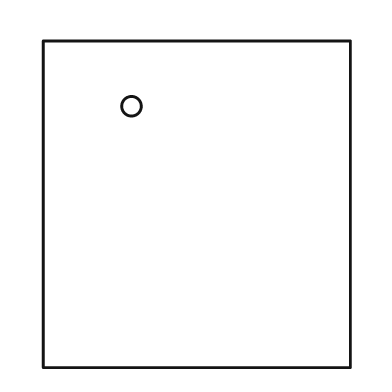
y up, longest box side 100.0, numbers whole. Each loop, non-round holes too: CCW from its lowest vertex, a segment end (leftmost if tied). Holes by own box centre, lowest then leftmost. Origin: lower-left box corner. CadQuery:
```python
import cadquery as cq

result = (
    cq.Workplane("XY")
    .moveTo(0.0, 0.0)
    .lineTo(94.0, 0.0)
    .lineTo(94.0, 100.0)
    .lineTo(0.0, 100.0)
    .close()
    .moveTo(27.0, 80.0)
    .circle(3.0)
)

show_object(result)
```